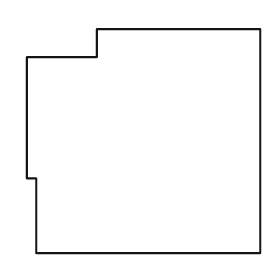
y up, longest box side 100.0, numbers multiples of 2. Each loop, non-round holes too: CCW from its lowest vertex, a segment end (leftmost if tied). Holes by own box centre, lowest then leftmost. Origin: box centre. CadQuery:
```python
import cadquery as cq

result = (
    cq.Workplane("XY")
    .moveTo(-46.0, -48.0)
    .lineTo(50.0, -48.0)
    .lineTo(50.0, 48.0)
    .lineTo(-20.0, 48.0)
    .lineTo(-20.0, 36.0)
    .lineTo(-50.0, 36.0)
    .lineTo(-50.0, -16.0)
    .lineTo(-46.0, -16.0)
    .close()
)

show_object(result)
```